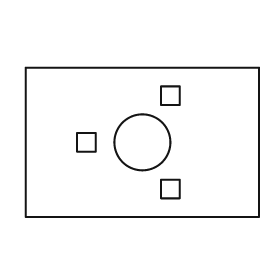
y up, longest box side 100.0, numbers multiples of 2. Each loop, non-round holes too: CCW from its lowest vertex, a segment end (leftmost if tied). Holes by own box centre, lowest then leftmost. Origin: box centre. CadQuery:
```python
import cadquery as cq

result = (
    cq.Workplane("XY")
    .moveTo(-50.0, -32.0)
    .lineTo(50.0, -32.0)
    .lineTo(50.0, 32.0)
    .lineTo(-50.0, 32.0)
    .close()
    .moveTo(8.0, -24.0)
    .lineTo(16.0, -24.0)
    .lineTo(16.0, -16.0)
    .lineTo(8.0, -16.0)
    .close()
    .moveTo(-28.0, -4.0)
    .lineTo(-20.0, -4.0)
    .lineTo(-20.0, 4.0)
    .lineTo(-28.0, 4.0)
    .close()
    .moveTo(0.0, 0.0)
    .circle(12.0)
    .moveTo(8.0, 16.0)
    .lineTo(16.0, 16.0)
    .lineTo(16.0, 24.0)
    .lineTo(8.0, 24.0)
    .close()
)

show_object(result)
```